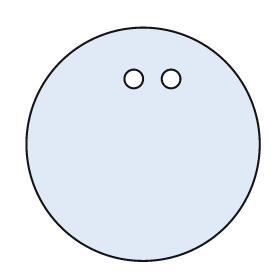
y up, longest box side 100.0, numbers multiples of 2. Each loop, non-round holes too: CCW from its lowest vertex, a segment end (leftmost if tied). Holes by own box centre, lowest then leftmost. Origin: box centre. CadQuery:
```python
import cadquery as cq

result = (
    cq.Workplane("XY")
    .moveTo(0.0, 0.0)
    .circle(50.0)
    .moveTo(-4.0, 28.0)
    .circle(4.0)
    .moveTo(12.0, 28.0)
    .circle(4.0)
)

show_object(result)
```